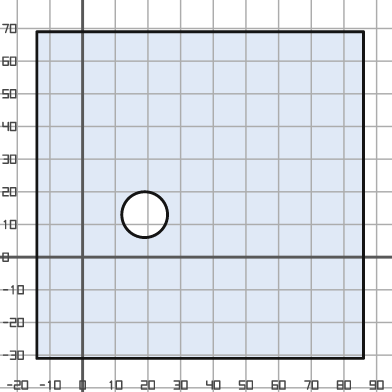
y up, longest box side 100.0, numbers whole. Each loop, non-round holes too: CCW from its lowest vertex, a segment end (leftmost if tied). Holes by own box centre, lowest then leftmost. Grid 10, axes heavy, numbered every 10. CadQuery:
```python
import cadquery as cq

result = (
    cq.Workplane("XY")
    .moveTo(-14.0, -31.0)
    .lineTo(86.0, -31.0)
    .lineTo(86.0, 69.0)
    .lineTo(-14.0, 69.0)
    .close()
    .moveTo(19.0, 13.0)
    .circle(7.0)
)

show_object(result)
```